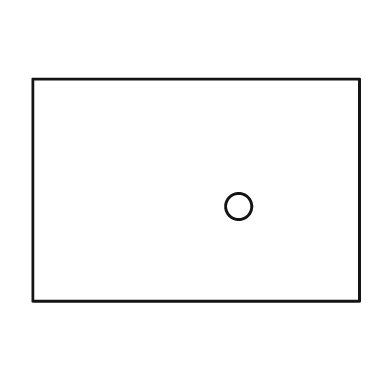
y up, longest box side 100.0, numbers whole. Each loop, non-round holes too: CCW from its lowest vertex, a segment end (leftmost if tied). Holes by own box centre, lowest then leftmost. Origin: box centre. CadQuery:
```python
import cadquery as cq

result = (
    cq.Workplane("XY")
    .moveTo(-50.0, -34.0)
    .lineTo(50.0, -34.0)
    .lineTo(50.0, 34.0)
    .lineTo(-50.0, 34.0)
    .close()
    .moveTo(13.0, -5.0)
    .circle(4.0)
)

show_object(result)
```